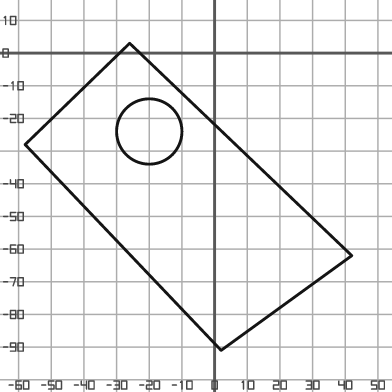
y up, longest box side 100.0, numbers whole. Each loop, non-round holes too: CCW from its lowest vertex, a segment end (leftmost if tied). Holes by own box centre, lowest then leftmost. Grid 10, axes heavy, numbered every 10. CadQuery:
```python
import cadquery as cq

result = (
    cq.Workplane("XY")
    .moveTo(2.0, -91.0)
    .lineTo(42.0, -62.0)
    .lineTo(-26.0, 3.0)
    .lineTo(-58.0, -28.0)
    .close()
    .moveTo(-20.0, -24.0)
    .circle(10.0)
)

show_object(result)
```